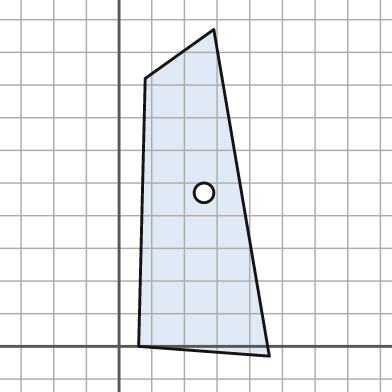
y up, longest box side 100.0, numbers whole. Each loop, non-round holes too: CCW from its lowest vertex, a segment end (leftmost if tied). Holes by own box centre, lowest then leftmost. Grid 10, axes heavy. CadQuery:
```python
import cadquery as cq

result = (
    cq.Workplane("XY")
    .moveTo(46.0, -3.0)
    .lineTo(29.0, 97.0)
    .lineTo(8.0, 82.0)
    .lineTo(6.0, 0.0)
    .close()
    .moveTo(26.0, 47.0)
    .circle(3.0)
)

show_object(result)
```